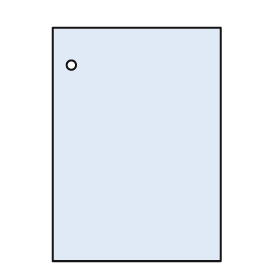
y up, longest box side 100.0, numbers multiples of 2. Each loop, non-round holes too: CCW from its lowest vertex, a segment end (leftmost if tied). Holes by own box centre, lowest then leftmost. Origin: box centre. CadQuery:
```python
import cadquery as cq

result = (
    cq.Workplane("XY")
    .moveTo(-36.0, -50.0)
    .lineTo(36.0, -50.0)
    .lineTo(36.0, 50.0)
    .lineTo(-36.0, 50.0)
    .close()
    .moveTo(-28.0, 34.0)
    .circle(2.0)
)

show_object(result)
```